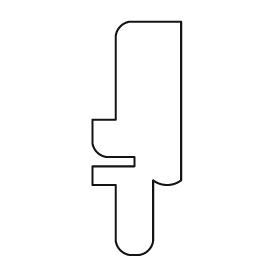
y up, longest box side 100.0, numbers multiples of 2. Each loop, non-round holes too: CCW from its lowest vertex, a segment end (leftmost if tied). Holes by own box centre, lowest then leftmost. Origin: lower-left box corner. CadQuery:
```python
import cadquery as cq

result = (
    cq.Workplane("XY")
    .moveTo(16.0, 0.0)
    .lineTo(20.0, 0.0)
    .threePointArc((24.0, 2.0), (26.0, 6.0))
    .lineTo(26.0, 32.0)
    .threePointArc((32.0, 30.0), (38.0, 32.0))
    .lineTo(38.0, 100.0)
    .lineTo(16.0, 100.0)
    .threePointArc((12.0, 98.0), (10.0, 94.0))
    .lineTo(10.0, 58.0)
    .lineTo(0.0, 58.0)
    .lineTo(0.0, 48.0)
    .threePointArc((2.0, 44.0), (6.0, 42.0))
    .lineTo(18.0, 42.0)
    .lineTo(18.0, 38.0)
    .lineTo(0.0, 38.0)
    .lineTo(0.0, 30.0)
    .lineTo(10.0, 30.0)
    .lineTo(10.0, 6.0)
    .threePointArc((12.0, 2.0), (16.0, 0.0))
    .close()
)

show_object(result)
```